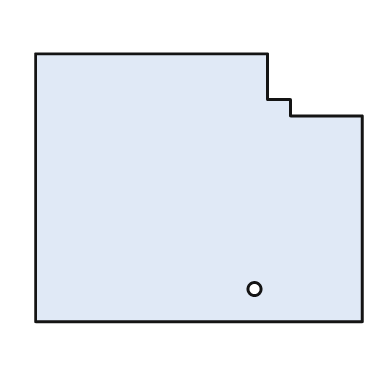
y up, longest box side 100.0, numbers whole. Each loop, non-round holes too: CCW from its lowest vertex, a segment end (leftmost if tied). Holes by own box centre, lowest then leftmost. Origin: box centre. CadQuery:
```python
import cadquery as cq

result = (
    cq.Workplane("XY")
    .moveTo(-50.0, -41.0)
    .lineTo(50.0, -41.0)
    .lineTo(50.0, 22.0)
    .lineTo(28.0, 22.0)
    .lineTo(28.0, 27.0)
    .lineTo(21.0, 27.0)
    .lineTo(21.0, 41.0)
    .lineTo(-50.0, 41.0)
    .close()
    .moveTo(17.0, -31.0)
    .circle(2.0)
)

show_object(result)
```